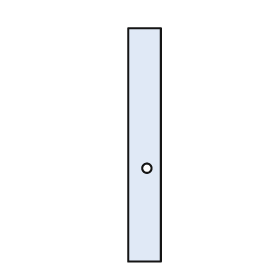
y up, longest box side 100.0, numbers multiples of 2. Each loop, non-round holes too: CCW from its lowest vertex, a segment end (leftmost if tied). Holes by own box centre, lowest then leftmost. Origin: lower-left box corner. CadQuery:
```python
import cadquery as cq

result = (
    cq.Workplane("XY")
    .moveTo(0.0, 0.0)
    .lineTo(14.0, 0.0)
    .lineTo(14.0, 100.0)
    .lineTo(0.0, 100.0)
    .close()
    .moveTo(8.0, 40.0)
    .circle(2.0)
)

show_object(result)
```